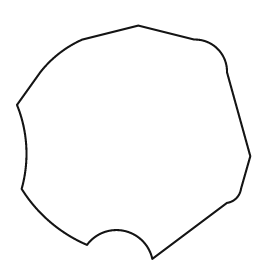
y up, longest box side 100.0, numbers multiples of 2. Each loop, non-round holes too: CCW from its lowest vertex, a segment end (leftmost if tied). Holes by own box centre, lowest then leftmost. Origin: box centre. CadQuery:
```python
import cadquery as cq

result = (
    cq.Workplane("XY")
    .moveTo(8.0, -50.0)
    .lineTo(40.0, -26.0)
    .threePointArc((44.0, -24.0), (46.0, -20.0))
    .lineTo(50.0, -6.0)
    .lineTo(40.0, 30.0)
    .threePointArc((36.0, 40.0), (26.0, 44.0))
    .lineTo(2.0, 50.0)
    .lineTo(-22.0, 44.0)
    .threePointArc((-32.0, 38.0), (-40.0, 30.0))
    .lineTo(-50.0, 16.0)
    .threePointArc((-46.0, -2.0), (-48.0, -20.0))
    .threePointArc((-36.0, -34.0), (-20.0, -44.0))
    .threePointArc((-4.0, -38.0), (8.0, -50.0))
    .close()
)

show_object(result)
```